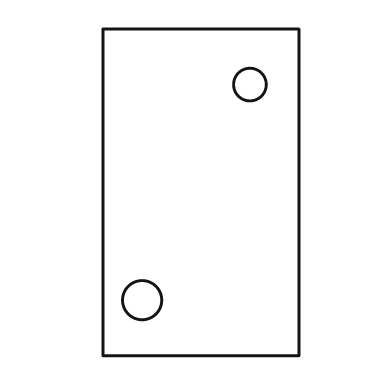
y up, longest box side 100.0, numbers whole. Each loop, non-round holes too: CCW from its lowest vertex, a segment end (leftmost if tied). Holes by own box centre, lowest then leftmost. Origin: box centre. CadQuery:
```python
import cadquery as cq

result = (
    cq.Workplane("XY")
    .moveTo(-30.0, -50.0)
    .lineTo(30.0, -50.0)
    .lineTo(30.0, 50.0)
    .lineTo(-30.0, 50.0)
    .close()
    .moveTo(-18.0, -33.0)
    .circle(6.0)
    .moveTo(15.0, 33.0)
    .circle(5.0)
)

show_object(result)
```